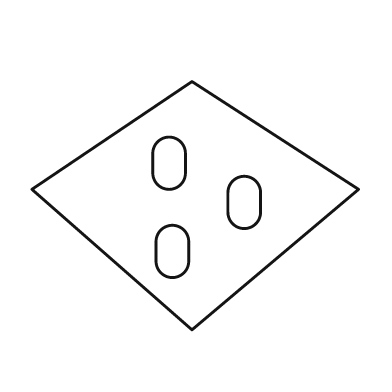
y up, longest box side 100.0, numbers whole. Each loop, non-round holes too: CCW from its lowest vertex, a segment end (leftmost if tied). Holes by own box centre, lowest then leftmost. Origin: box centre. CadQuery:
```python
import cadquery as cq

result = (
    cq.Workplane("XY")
    .moveTo(-1.0, -38.0)
    .lineTo(50.0, 5.0)
    .lineTo(-1.0, 38.0)
    .lineTo(-50.0, 5.0)
    .close()
    .moveTo(-12.0, -17.0)
    .threePointArc((-7.0, -22.0), (-2.0, -17.0))
    .lineTo(-2.0, -11.0)
    .threePointArc((-7.0, -6.0), (-12.0, -11.0))
    .close()
    .moveTo(10.0, -2.0)
    .threePointArc((15.0, -7.0), (20.0, -2.0))
    .lineTo(20.0, 4.0)
    .threePointArc((15.0, 9.0), (10.0, 4.0))
    .close()
    .moveTo(-13.0, 10.0)
    .threePointArc((-8.0, 5.0), (-3.0, 10.0))
    .lineTo(-3.0, 16.0)
    .threePointArc((-8.0, 21.0), (-13.0, 16.0))
    .close()
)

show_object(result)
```